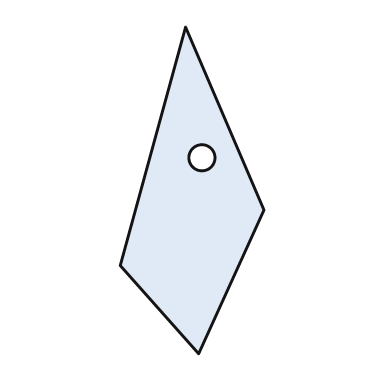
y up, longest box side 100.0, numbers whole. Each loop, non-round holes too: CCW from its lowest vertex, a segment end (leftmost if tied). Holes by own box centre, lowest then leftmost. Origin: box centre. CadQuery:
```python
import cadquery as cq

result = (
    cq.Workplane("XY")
    .moveTo(2.0, -50.0)
    .lineTo(22.0, -6.0)
    .lineTo(-2.0, 50.0)
    .lineTo(-22.0, -23.0)
    .close()
    .moveTo(3.0, 10.0)
    .circle(4.0)
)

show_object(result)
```